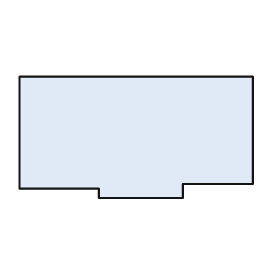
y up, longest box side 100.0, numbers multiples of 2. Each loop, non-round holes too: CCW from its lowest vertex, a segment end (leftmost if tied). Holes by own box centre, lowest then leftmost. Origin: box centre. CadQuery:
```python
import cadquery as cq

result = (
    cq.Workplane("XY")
    .moveTo(-16.0, -26.0)
    .lineTo(20.0, -26.0)
    .lineTo(20.0, -20.0)
    .lineTo(50.0, -20.0)
    .lineTo(50.0, 26.0)
    .lineTo(-50.0, 26.0)
    .lineTo(-50.0, -22.0)
    .lineTo(-16.0, -22.0)
    .close()
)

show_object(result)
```